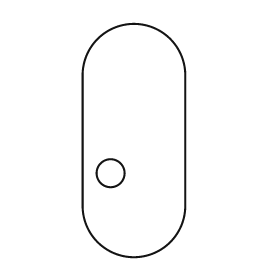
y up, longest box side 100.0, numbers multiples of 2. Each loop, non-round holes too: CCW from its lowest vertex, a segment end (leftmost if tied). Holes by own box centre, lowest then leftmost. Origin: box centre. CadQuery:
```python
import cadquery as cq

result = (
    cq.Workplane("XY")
    .moveTo(-22.0, -28.0)
    .threePointArc((0.0, -50.0), (22.0, -28.0))
    .lineTo(22.0, 28.0)
    .threePointArc((0.0, 50.0), (-22.0, 28.0))
    .close()
    .moveTo(-10.0, -14.0)
    .circle(6.0)
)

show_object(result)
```